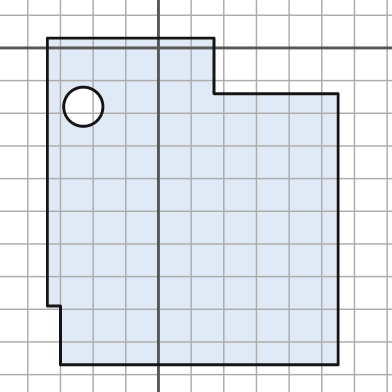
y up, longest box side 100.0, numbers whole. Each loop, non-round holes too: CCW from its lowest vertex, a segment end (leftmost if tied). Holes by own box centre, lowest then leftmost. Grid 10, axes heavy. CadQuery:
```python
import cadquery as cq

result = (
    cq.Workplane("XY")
    .moveTo(-30.0, -97.0)
    .lineTo(55.0, -97.0)
    .lineTo(55.0, -14.0)
    .lineTo(17.0, -14.0)
    .lineTo(17.0, 3.0)
    .lineTo(-34.0, 3.0)
    .lineTo(-34.0, -79.0)
    .lineTo(-30.0, -79.0)
    .close()
    .moveTo(-23.0, -18.0)
    .circle(6.0)
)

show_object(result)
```